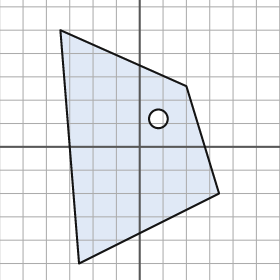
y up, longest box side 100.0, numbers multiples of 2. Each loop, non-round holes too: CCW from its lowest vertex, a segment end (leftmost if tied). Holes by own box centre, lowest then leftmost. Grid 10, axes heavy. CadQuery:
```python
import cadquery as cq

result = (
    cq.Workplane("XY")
    .moveTo(-26.0, -50.0)
    .lineTo(34.0, -20.0)
    .lineTo(20.0, 26.0)
    .lineTo(-34.0, 50.0)
    .close()
    .moveTo(8.0, 12.0)
    .circle(4.0)
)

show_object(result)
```